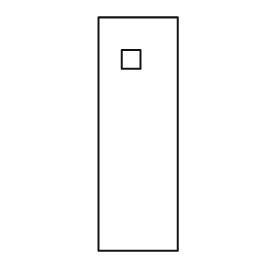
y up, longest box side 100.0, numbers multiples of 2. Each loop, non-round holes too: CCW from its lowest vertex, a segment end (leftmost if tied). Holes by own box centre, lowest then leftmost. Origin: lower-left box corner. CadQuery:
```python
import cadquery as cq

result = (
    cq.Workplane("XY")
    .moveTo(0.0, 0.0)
    .lineTo(34.0, 0.0)
    .lineTo(34.0, 100.0)
    .lineTo(0.0, 100.0)
    .close()
    .moveTo(10.0, 78.0)
    .lineTo(18.0, 78.0)
    .lineTo(18.0, 86.0)
    .lineTo(10.0, 86.0)
    .close()
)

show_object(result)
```